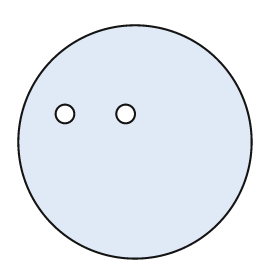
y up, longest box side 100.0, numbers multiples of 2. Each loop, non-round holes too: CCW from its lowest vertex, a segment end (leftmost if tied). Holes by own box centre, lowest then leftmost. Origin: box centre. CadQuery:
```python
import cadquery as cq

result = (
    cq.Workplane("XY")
    .moveTo(0.0, 0.0)
    .circle(50.0)
    .moveTo(-30.0, 12.0)
    .circle(4.0)
    .moveTo(-4.0, 12.0)
    .circle(4.0)
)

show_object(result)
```